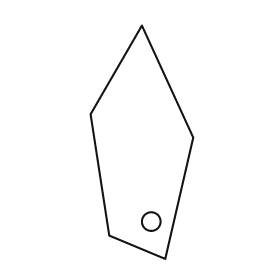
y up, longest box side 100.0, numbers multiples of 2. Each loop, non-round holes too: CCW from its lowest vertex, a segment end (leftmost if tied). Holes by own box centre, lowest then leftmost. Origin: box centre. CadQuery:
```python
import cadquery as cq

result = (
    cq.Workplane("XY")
    .moveTo(10.0, -50.0)
    .lineTo(22.0, 2.0)
    .lineTo(0.0, 50.0)
    .lineTo(-22.0, 12.0)
    .lineTo(-14.0, -40.0)
    .close()
    .moveTo(4.0, -34.0)
    .circle(4.0)
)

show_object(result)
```